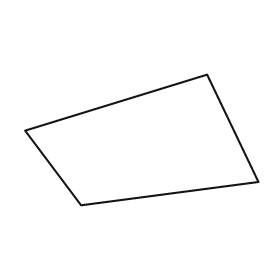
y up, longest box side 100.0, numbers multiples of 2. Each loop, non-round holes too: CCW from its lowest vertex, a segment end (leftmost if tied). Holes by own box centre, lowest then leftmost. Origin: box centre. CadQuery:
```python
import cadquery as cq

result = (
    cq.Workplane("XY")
    .moveTo(-26.0, -28.0)
    .lineTo(50.0, -18.0)
    .lineTo(28.0, 28.0)
    .lineTo(-50.0, 4.0)
    .close()
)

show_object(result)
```